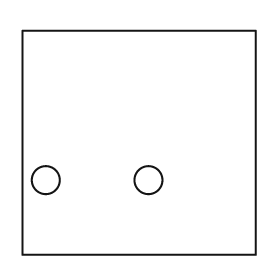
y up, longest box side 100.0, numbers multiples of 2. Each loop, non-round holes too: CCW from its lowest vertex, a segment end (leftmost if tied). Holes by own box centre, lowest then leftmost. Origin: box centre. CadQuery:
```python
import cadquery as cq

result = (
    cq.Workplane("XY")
    .moveTo(-50.0, -48.0)
    .lineTo(50.0, -48.0)
    .lineTo(50.0, 48.0)
    .lineTo(-50.0, 48.0)
    .close()
    .moveTo(-40.0, -16.0)
    .circle(6.0)
    .moveTo(4.0, -16.0)
    .circle(6.0)
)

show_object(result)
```